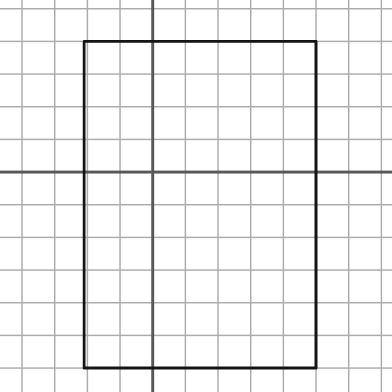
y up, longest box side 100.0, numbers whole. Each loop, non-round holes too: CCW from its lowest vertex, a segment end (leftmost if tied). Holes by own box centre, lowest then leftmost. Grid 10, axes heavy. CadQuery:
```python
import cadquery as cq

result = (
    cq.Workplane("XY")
    .moveTo(-21.0, -60.0)
    .lineTo(50.0, -60.0)
    .lineTo(50.0, 40.0)
    .lineTo(-21.0, 40.0)
    .close()
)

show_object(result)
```